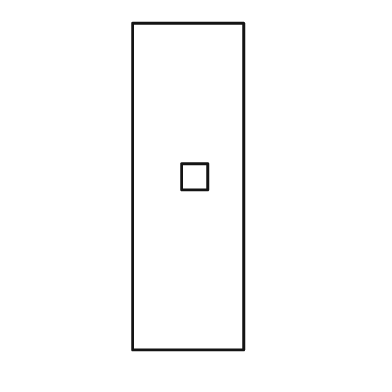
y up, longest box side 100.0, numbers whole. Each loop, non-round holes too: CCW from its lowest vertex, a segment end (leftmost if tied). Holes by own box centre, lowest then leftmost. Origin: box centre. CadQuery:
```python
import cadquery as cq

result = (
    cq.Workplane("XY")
    .moveTo(-17.0, -50.0)
    .lineTo(17.0, -50.0)
    .lineTo(17.0, 50.0)
    .lineTo(-17.0, 50.0)
    .close()
    .moveTo(-2.0, -1.0)
    .lineTo(6.0, -1.0)
    .lineTo(6.0, 7.0)
    .lineTo(-2.0, 7.0)
    .close()
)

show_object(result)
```